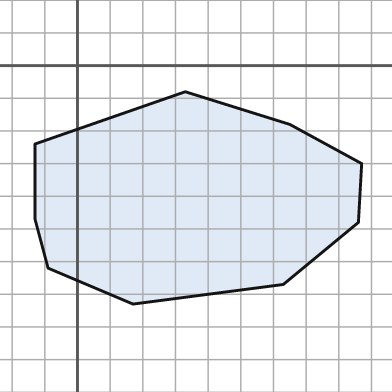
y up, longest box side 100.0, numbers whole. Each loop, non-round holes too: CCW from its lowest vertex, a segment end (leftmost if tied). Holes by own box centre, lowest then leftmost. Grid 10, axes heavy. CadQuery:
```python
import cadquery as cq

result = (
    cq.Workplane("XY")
    .moveTo(17.0, -73.0)
    .lineTo(63.0, -67.0)
    .lineTo(86.0, -48.0)
    .lineTo(87.0, -30.0)
    .lineTo(65.0, -18.0)
    .lineTo(33.0, -8.0)
    .lineTo(-13.0, -24.0)
    .lineTo(-13.0, -47.0)
    .lineTo(-9.0, -62.0)
    .close()
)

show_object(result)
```